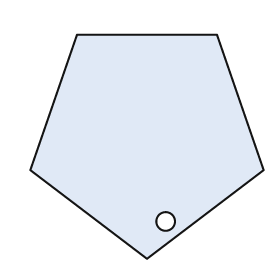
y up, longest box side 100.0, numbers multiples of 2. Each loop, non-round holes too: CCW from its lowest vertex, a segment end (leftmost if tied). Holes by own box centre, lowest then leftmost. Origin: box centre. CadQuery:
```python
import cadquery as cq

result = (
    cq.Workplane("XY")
    .moveTo(0.0, -48.0)
    .lineTo(50.0, -10.0)
    .lineTo(30.0, 48.0)
    .lineTo(-30.0, 48.0)
    .lineTo(-50.0, -10.0)
    .close()
    .moveTo(8.0, -32.0)
    .circle(4.0)
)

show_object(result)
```